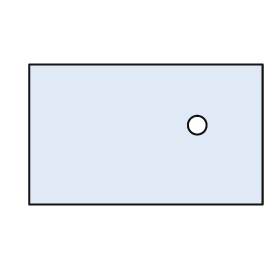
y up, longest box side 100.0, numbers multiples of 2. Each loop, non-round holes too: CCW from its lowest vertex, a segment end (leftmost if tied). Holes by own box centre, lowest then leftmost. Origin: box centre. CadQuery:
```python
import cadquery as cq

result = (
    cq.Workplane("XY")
    .moveTo(-50.0, -30.0)
    .lineTo(50.0, -30.0)
    .lineTo(50.0, 30.0)
    .lineTo(-50.0, 30.0)
    .close()
    .moveTo(22.0, 4.0)
    .circle(4.0)
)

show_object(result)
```